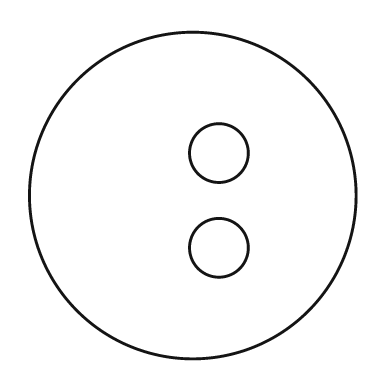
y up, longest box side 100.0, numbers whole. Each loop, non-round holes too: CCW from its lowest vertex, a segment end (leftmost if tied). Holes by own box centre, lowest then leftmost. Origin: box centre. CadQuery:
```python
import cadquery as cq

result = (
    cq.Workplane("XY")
    .moveTo(0.0, 0.0)
    .circle(50.0)
    .moveTo(8.0, -16.0)
    .circle(9.0)
    .moveTo(8.0, 13.0)
    .circle(9.0)
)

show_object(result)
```